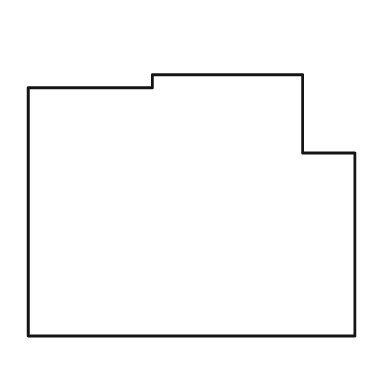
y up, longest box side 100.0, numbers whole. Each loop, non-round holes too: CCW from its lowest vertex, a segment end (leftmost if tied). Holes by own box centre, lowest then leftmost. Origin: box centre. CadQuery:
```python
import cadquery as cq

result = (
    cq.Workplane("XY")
    .moveTo(-50.0, -40.0)
    .lineTo(50.0, -40.0)
    .lineTo(50.0, 16.0)
    .lineTo(34.0, 16.0)
    .lineTo(34.0, 40.0)
    .lineTo(-12.0, 40.0)
    .lineTo(-12.0, 36.0)
    .lineTo(-50.0, 36.0)
    .close()
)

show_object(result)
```